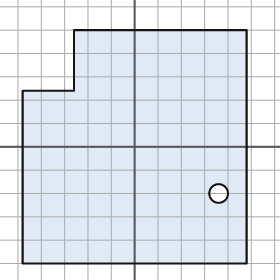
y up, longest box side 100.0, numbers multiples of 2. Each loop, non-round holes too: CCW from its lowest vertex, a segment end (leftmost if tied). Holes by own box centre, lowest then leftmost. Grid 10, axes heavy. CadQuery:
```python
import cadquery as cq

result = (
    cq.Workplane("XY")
    .moveTo(-48.0, -50.0)
    .lineTo(48.0, -50.0)
    .lineTo(48.0, 50.0)
    .lineTo(-26.0, 50.0)
    .lineTo(-26.0, 24.0)
    .lineTo(-48.0, 24.0)
    .close()
    .moveTo(36.0, -20.0)
    .circle(4.0)
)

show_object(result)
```